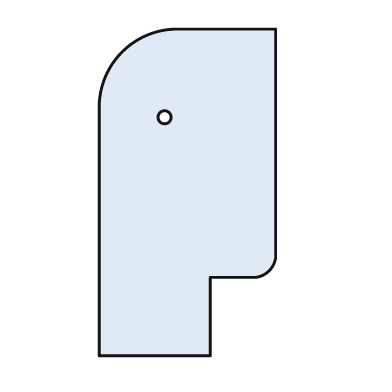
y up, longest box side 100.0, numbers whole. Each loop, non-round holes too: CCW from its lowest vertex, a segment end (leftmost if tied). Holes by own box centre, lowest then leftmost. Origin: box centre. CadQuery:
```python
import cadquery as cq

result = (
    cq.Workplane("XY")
    .moveTo(-27.0, -50.0)
    .lineTo(7.0, -50.0)
    .lineTo(7.0, -26.0)
    .lineTo(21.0, -26.0)
    .threePointArc((25.0, -24.0), (27.0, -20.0))
    .lineTo(27.0, 50.0)
    .lineTo(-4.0, 50.0)
    .threePointArc((-20.0, 43.0), (-27.0, 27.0))
    .close()
    .moveTo(-7.0, 23.0)
    .circle(2.0)
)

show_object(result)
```